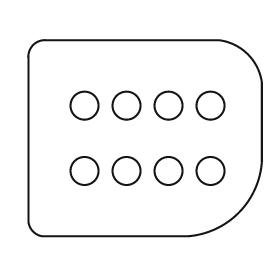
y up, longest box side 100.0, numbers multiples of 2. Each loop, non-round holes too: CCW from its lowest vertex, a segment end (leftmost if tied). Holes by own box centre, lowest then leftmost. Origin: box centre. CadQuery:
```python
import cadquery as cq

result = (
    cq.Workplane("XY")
    .moveTo(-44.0, -42.0)
    .lineTo(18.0, -42.0)
    .threePointArc((40.0, -32.0), (50.0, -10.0))
    .lineTo(50.0, 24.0)
    .threePointArc((44.0, 36.0), (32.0, 42.0))
    .lineTo(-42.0, 42.0)
    .threePointArc((-48.0, 40.0), (-50.0, 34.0))
    .lineTo(-50.0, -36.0)
    .threePointArc((-48.0, -40.0), (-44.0, -42.0))
    .close()
    .moveTo(-26.0, -14.0)
    .circle(6.0)
    .moveTo(-8.0, -14.0)
    .circle(6.0)
    .moveTo(10.0, -14.0)
    .circle(6.0)
    .moveTo(28.0, -14.0)
    .circle(6.0)
    .moveTo(-26.0, 14.0)
    .circle(6.0)
    .moveTo(-8.0, 14.0)
    .circle(6.0)
    .moveTo(10.0, 14.0)
    .circle(6.0)
    .moveTo(28.0, 14.0)
    .circle(6.0)
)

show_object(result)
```